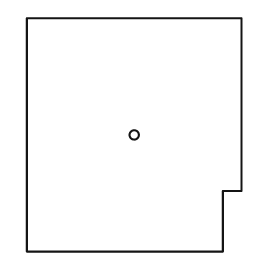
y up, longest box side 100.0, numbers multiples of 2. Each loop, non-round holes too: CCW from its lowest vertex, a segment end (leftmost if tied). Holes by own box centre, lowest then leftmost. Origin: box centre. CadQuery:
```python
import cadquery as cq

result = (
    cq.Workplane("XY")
    .moveTo(-46.0, -50.0)
    .lineTo(38.0, -50.0)
    .lineTo(38.0, -24.0)
    .lineTo(46.0, -24.0)
    .lineTo(46.0, 50.0)
    .lineTo(-46.0, 50.0)
    .close()
    .moveTo(0.0, 0.0)
    .circle(2.0)
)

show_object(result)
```